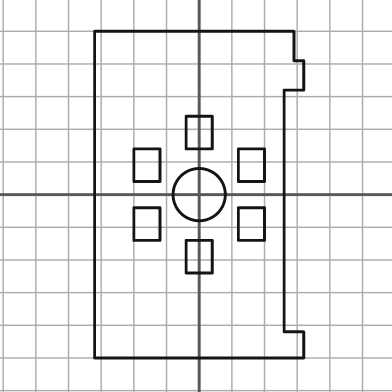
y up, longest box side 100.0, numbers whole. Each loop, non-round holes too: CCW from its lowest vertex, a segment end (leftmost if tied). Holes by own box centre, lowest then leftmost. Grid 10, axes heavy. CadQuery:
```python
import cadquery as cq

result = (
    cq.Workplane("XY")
    .moveTo(-32.0, -50.0)
    .lineTo(32.0, -50.0)
    .lineTo(32.0, -42.0)
    .lineTo(26.0, -42.0)
    .lineTo(26.0, 32.0)
    .lineTo(32.0, 32.0)
    .lineTo(32.0, 41.0)
    .lineTo(29.0, 41.0)
    .lineTo(29.0, 50.0)
    .lineTo(-32.0, 50.0)
    .close()
    .moveTo(-4.0, -24.0)
    .lineTo(4.0, -24.0)
    .lineTo(4.0, -14.0)
    .lineTo(-4.0, -14.0)
    .close()
    .moveTo(-20.0, -14.0)
    .lineTo(-12.0, -14.0)
    .lineTo(-12.0, -4.0)
    .lineTo(-20.0, -4.0)
    .close()
    .moveTo(12.0, -14.0)
    .lineTo(20.0, -14.0)
    .lineTo(20.0, -4.0)
    .lineTo(12.0, -4.0)
    .close()
    .moveTo(0.0, 0.0)
    .circle(8.0)
    .moveTo(-20.0, 4.0)
    .lineTo(-12.0, 4.0)
    .lineTo(-12.0, 14.0)
    .lineTo(-20.0, 14.0)
    .close()
    .moveTo(12.0, 4.0)
    .lineTo(20.0, 4.0)
    .lineTo(20.0, 14.0)
    .lineTo(12.0, 14.0)
    .close()
    .moveTo(-4.0, 14.0)
    .lineTo(4.0, 14.0)
    .lineTo(4.0, 24.0)
    .lineTo(-4.0, 24.0)
    .close()
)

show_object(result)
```